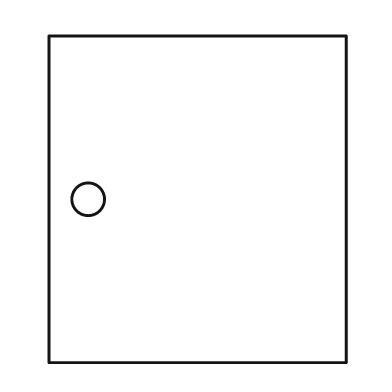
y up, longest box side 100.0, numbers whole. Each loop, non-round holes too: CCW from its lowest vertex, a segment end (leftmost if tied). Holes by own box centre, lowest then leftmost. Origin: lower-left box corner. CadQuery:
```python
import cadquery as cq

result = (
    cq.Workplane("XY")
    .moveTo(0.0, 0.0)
    .lineTo(91.0, 0.0)
    .lineTo(91.0, 100.0)
    .lineTo(0.0, 100.0)
    .close()
    .moveTo(12.0, 50.0)
    .circle(5.0)
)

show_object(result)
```